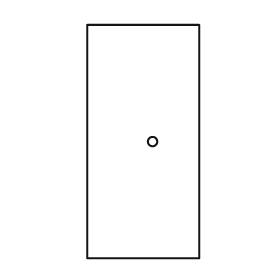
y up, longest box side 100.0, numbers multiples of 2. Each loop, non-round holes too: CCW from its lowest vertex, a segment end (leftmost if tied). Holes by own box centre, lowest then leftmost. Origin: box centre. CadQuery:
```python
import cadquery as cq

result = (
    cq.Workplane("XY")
    .moveTo(-24.0, -50.0)
    .lineTo(24.0, -50.0)
    .lineTo(24.0, 50.0)
    .lineTo(-24.0, 50.0)
    .close()
    .moveTo(4.0, 0.0)
    .circle(2.0)
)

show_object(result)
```